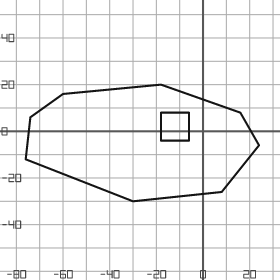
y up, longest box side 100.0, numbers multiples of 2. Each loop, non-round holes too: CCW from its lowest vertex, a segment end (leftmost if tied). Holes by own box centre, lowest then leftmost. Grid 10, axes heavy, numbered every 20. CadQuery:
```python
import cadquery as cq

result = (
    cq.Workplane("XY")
    .moveTo(-30.0, -30.0)
    .lineTo(8.0, -26.0)
    .lineTo(24.0, -6.0)
    .lineTo(16.0, 8.0)
    .lineTo(-18.0, 20.0)
    .lineTo(-60.0, 16.0)
    .lineTo(-74.0, 6.0)
    .lineTo(-76.0, -12.0)
    .close()
    .moveTo(-18.0, -4.0)
    .lineTo(-6.0, -4.0)
    .lineTo(-6.0, 8.0)
    .lineTo(-18.0, 8.0)
    .close()
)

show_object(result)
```